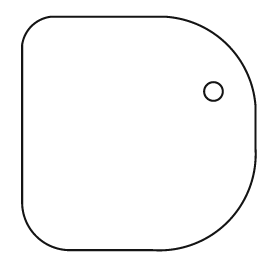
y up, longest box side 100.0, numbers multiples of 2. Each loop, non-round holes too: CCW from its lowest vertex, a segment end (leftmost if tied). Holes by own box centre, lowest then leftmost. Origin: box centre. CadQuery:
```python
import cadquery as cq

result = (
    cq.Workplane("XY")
    .moveTo(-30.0, -50.0)
    .lineTo(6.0, -50.0)
    .threePointArc((38.0, -38.0), (50.0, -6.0))
    .lineTo(50.0, 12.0)
    .threePointArc((38.0, 38.0), (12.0, 50.0))
    .lineTo(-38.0, 50.0)
    .threePointArc((-46.0, 46.0), (-50.0, 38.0))
    .lineTo(-50.0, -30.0)
    .threePointArc((-44.0, -44.0), (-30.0, -50.0))
    .close()
    .moveTo(32.0, 18.0)
    .circle(4.0)
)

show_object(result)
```